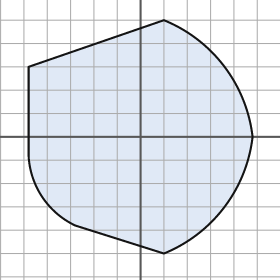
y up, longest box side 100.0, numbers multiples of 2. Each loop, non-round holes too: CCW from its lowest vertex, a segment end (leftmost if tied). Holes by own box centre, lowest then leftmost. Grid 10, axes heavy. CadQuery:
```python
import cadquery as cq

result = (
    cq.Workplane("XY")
    .moveTo(10.0, -50.0)
    .threePointArc((36.0, -30.0), (48.0, 0.0))
    .threePointArc((36.0, 30.0), (10.0, 50.0))
    .lineTo(-48.0, 30.0)
    .lineTo(-48.0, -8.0)
    .threePointArc((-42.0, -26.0), (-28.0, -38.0))
    .close()
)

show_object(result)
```